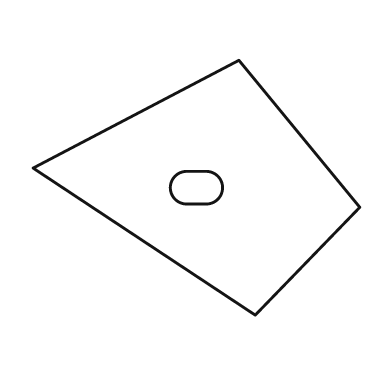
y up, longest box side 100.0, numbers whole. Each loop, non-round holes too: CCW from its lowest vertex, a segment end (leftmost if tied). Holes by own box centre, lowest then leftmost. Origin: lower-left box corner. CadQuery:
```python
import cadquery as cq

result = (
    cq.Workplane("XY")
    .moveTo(68.0, 0.0)
    .lineTo(100.0, 33.0)
    .lineTo(63.0, 78.0)
    .lineTo(0.0, 45.0)
    .close()
    .moveTo(47.0, 34.0)
    .lineTo(53.0, 34.0)
    .threePointArc((58.0, 39.0), (53.0, 44.0))
    .lineTo(47.0, 44.0)
    .threePointArc((42.0, 39.0), (47.0, 34.0))
    .close()
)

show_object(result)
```